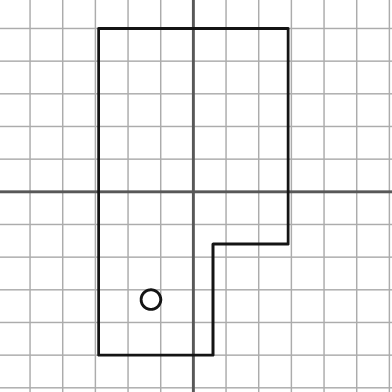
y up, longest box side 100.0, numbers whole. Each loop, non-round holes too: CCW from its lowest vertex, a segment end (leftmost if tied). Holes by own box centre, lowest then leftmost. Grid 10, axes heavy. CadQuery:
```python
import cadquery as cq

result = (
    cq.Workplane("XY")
    .moveTo(-29.0, -50.0)
    .lineTo(6.0, -50.0)
    .lineTo(6.0, -16.0)
    .lineTo(29.0, -16.0)
    .lineTo(29.0, 50.0)
    .lineTo(-29.0, 50.0)
    .close()
    .moveTo(-13.0, -33.0)
    .circle(3.0)
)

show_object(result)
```